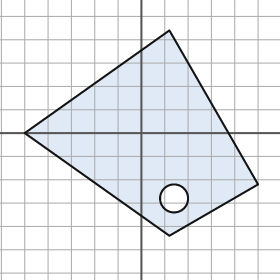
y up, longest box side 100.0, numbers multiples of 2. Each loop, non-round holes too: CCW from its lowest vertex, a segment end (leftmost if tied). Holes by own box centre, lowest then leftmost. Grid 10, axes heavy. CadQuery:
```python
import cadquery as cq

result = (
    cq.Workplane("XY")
    .moveTo(12.0, -44.0)
    .lineTo(50.0, -22.0)
    .lineTo(12.0, 44.0)
    .lineTo(-50.0, 0.0)
    .close()
    .moveTo(14.0, -28.0)
    .circle(6.0)
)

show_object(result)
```